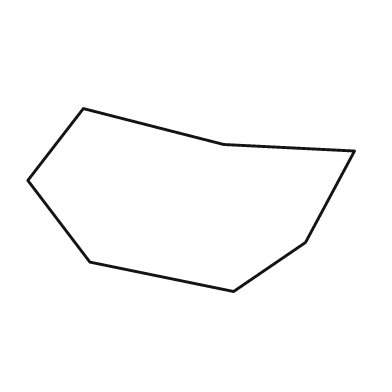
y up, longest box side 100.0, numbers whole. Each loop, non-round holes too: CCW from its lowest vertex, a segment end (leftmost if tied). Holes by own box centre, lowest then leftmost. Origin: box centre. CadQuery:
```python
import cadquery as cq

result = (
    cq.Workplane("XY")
    .moveTo(13.0, -28.0)
    .lineTo(35.0, -13.0)
    .lineTo(50.0, 15.0)
    .lineTo(10.0, 17.0)
    .lineTo(-33.0, 28.0)
    .lineTo(-50.0, 6.0)
    .lineTo(-31.0, -19.0)
    .close()
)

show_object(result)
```